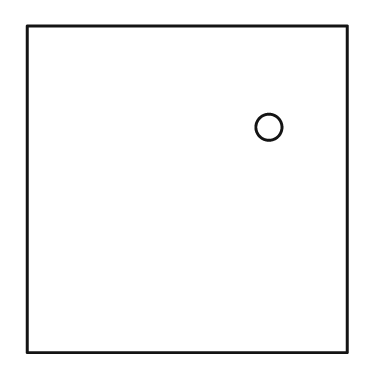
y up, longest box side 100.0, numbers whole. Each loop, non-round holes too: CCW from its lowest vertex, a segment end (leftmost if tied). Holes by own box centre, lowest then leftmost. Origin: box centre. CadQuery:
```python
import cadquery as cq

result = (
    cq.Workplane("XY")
    .moveTo(-49.0, -50.0)
    .lineTo(49.0, -50.0)
    .lineTo(49.0, 50.0)
    .lineTo(-49.0, 50.0)
    .close()
    .moveTo(25.0, 19.0)
    .circle(4.0)
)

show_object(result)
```